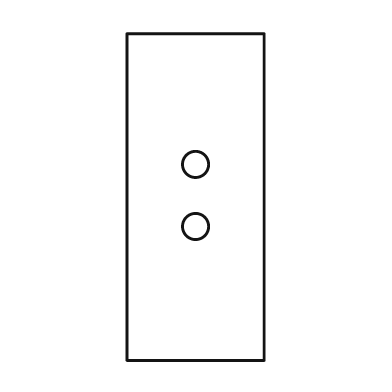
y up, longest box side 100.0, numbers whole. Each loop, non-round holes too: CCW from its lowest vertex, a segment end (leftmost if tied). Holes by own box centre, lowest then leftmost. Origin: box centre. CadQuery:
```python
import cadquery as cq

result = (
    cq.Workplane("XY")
    .moveTo(-21.0, -50.0)
    .lineTo(21.0, -50.0)
    .lineTo(21.0, 50.0)
    .lineTo(-21.0, 50.0)
    .close()
    .moveTo(0.0, -9.0)
    .circle(4.0)
    .moveTo(0.0, 10.0)
    .circle(4.0)
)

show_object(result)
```